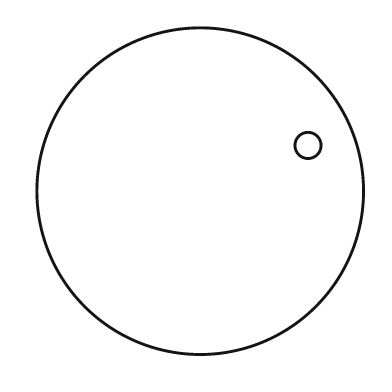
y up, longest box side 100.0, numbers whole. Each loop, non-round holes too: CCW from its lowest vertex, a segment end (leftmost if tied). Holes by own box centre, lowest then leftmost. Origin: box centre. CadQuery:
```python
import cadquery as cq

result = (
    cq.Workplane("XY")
    .moveTo(0.0, 0.0)
    .circle(50.0)
    .moveTo(33.0, 14.0)
    .circle(4.0)
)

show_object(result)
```